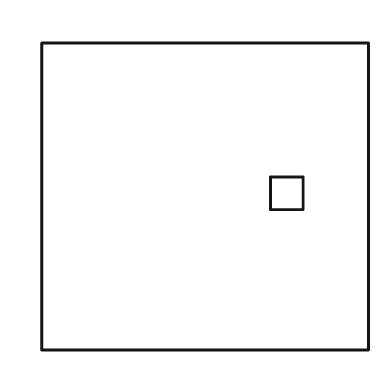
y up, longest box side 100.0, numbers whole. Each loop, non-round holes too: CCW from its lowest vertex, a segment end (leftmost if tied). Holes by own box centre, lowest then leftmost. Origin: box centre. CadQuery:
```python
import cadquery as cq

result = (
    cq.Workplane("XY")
    .moveTo(-50.0, -47.0)
    .lineTo(50.0, -47.0)
    .lineTo(50.0, 47.0)
    .lineTo(-50.0, 47.0)
    .close()
    .moveTo(20.0, -4.0)
    .lineTo(30.0, -4.0)
    .lineTo(30.0, 6.0)
    .lineTo(20.0, 6.0)
    .close()
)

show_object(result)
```